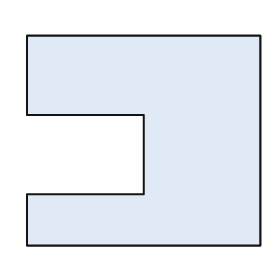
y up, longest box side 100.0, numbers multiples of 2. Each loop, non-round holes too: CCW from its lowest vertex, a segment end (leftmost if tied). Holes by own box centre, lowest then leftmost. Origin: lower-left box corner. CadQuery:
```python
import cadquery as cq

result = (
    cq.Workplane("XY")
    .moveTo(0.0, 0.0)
    .lineTo(100.0, 0.0)
    .lineTo(100.0, 90.0)
    .lineTo(0.0, 90.0)
    .lineTo(0.0, 56.0)
    .lineTo(50.0, 56.0)
    .lineTo(50.0, 22.0)
    .lineTo(0.0, 22.0)
    .close()
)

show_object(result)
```